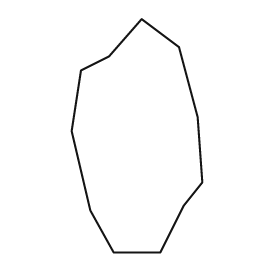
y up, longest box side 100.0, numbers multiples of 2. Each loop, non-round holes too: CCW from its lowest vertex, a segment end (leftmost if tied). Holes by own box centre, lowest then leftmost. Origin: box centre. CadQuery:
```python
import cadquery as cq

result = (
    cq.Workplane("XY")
    .moveTo(-10.0, -50.0)
    .lineTo(10.0, -50.0)
    .lineTo(20.0, -30.0)
    .lineTo(28.0, -20.0)
    .lineTo(26.0, 8.0)
    .lineTo(18.0, 38.0)
    .lineTo(2.0, 50.0)
    .lineTo(-12.0, 34.0)
    .lineTo(-24.0, 28.0)
    .lineTo(-28.0, 2.0)
    .lineTo(-20.0, -32.0)
    .close()
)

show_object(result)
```